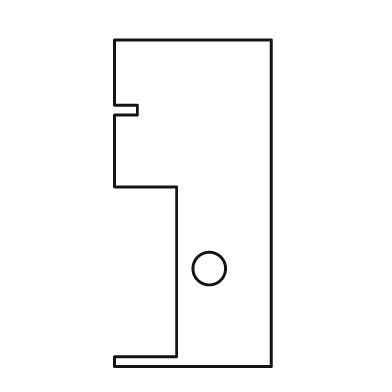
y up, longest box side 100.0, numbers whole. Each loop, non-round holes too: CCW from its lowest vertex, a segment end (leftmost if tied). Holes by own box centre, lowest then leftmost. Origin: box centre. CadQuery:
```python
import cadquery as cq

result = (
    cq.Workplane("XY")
    .moveTo(-24.0, -50.0)
    .lineTo(24.0, -50.0)
    .lineTo(24.0, 50.0)
    .lineTo(-24.0, 50.0)
    .lineTo(-24.0, 30.0)
    .lineTo(-17.0, 30.0)
    .lineTo(-17.0, 27.0)
    .lineTo(-24.0, 27.0)
    .lineTo(-24.0, 5.0)
    .lineTo(-5.0, 5.0)
    .lineTo(-5.0, -47.0)
    .lineTo(-24.0, -47.0)
    .close()
    .moveTo(5.0, -20.0)
    .circle(5.0)
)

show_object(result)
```